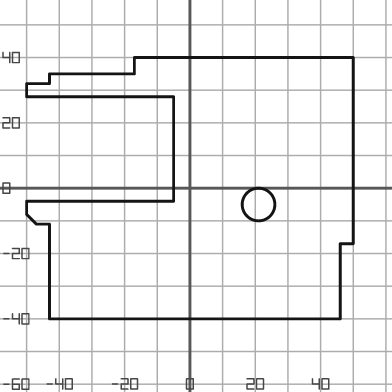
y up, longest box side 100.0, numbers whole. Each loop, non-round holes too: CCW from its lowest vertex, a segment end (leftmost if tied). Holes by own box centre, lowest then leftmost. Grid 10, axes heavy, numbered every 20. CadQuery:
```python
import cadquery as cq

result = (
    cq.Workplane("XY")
    .moveTo(-43.0, -40.0)
    .lineTo(46.0, -40.0)
    .lineTo(46.0, -17.0)
    .lineTo(50.0, -17.0)
    .lineTo(50.0, 40.0)
    .lineTo(-17.0, 40.0)
    .lineTo(-17.0, 35.0)
    .lineTo(-43.0, 35.0)
    .lineTo(-43.0, 32.0)
    .lineTo(-50.0, 32.0)
    .lineTo(-50.0, 28.0)
    .lineTo(-5.0, 28.0)
    .lineTo(-5.0, -4.0)
    .lineTo(-50.0, -4.0)
    .lineTo(-50.0, -8.0)
    .lineTo(-47.0, -11.0)
    .lineTo(-43.0, -11.0)
    .close()
    .moveTo(21.0, -5.0)
    .circle(5.0)
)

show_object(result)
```